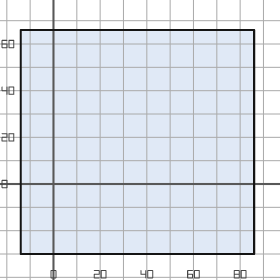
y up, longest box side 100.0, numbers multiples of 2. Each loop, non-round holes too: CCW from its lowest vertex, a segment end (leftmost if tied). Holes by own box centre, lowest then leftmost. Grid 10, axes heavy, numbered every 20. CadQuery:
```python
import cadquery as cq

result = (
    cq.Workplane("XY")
    .moveTo(-14.0, -30.0)
    .lineTo(86.0, -30.0)
    .lineTo(86.0, 66.0)
    .lineTo(-14.0, 66.0)
    .close()
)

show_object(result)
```